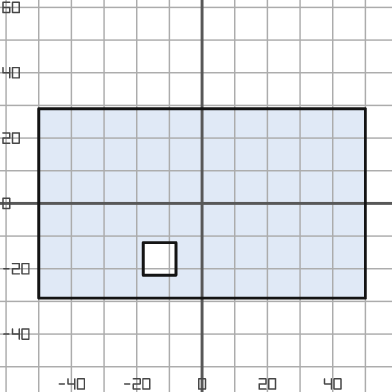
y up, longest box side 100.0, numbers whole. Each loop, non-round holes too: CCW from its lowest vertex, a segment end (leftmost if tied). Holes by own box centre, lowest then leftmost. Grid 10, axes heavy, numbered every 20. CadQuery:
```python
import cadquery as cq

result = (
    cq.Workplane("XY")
    .moveTo(-50.0, -29.0)
    .lineTo(50.0, -29.0)
    .lineTo(50.0, 29.0)
    .lineTo(-50.0, 29.0)
    .close()
    .moveTo(-18.0, -22.0)
    .lineTo(-8.0, -22.0)
    .lineTo(-8.0, -12.0)
    .lineTo(-18.0, -12.0)
    .close()
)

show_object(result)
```